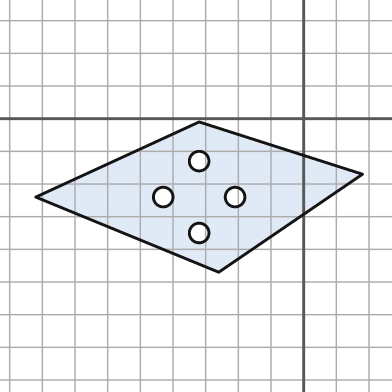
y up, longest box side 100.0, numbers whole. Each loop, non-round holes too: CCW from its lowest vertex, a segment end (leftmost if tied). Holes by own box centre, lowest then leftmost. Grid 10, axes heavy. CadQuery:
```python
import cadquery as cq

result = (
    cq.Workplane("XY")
    .moveTo(-26.0, -47.0)
    .lineTo(18.0, -17.0)
    .lineTo(-32.0, -1.0)
    .lineTo(-82.0, -24.0)
    .close()
    .moveTo(-32.0, -35.0)
    .circle(3.0)
    .moveTo(-43.0, -24.0)
    .circle(3.0)
    .moveTo(-21.0, -24.0)
    .circle(3.0)
    .moveTo(-32.0, -13.0)
    .circle(3.0)
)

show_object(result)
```